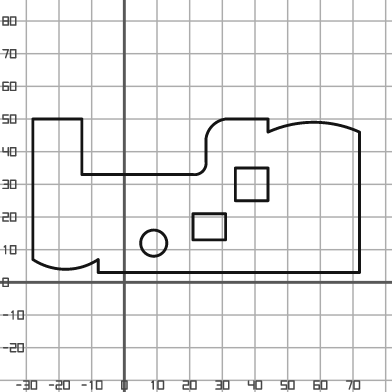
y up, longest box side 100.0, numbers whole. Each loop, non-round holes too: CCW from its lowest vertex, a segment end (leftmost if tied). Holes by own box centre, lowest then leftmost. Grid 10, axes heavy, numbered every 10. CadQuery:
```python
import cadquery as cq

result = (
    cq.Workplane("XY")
    .moveTo(-8.0, 3.0)
    .lineTo(72.0, 3.0)
    .lineTo(72.0, 46.0)
    .threePointArc((58.0, 49.0), (44.0, 46.0))
    .lineTo(44.0, 50.0)
    .lineTo(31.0, 50.0)
    .threePointArc((27.0, 48.0), (25.0, 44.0))
    .lineTo(25.0, 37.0)
    .threePointArc((24.0, 34.0), (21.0, 33.0))
    .lineTo(-13.0, 33.0)
    .lineTo(-13.0, 50.0)
    .lineTo(-28.0, 50.0)
    .lineTo(-28.0, 7.0)
    .threePointArc((-18.0, 4.0), (-8.0, 7.0))
    .close()
    .moveTo(9.0, 12.0)
    .circle(4.0)
    .moveTo(21.0, 13.0)
    .lineTo(31.0, 13.0)
    .lineTo(31.0, 21.0)
    .lineTo(21.0, 21.0)
    .close()
    .moveTo(34.0, 25.0)
    .lineTo(44.0, 25.0)
    .lineTo(44.0, 35.0)
    .lineTo(34.0, 35.0)
    .close()
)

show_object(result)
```